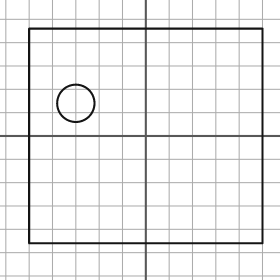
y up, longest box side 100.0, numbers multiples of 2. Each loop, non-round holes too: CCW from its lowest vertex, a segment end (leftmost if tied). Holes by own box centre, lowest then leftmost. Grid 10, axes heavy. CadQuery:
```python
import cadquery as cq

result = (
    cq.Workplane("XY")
    .moveTo(-50.0, -46.0)
    .lineTo(50.0, -46.0)
    .lineTo(50.0, 46.0)
    .lineTo(-50.0, 46.0)
    .close()
    .moveTo(-30.0, 14.0)
    .circle(8.0)
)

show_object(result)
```